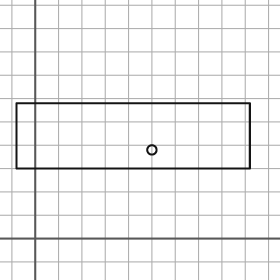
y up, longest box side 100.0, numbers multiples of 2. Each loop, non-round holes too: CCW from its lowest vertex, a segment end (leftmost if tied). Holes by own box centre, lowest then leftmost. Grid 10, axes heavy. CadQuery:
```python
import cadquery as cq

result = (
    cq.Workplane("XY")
    .moveTo(-8.0, 30.0)
    .lineTo(92.0, 30.0)
    .lineTo(92.0, 58.0)
    .lineTo(-8.0, 58.0)
    .close()
    .moveTo(50.0, 38.0)
    .circle(2.0)
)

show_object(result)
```